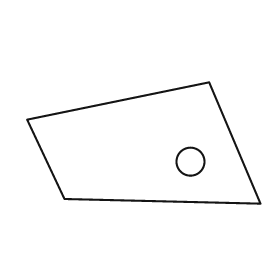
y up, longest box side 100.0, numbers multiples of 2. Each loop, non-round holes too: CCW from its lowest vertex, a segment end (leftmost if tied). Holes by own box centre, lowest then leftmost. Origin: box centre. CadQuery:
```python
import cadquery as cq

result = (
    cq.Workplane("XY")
    .moveTo(50.0, -26.0)
    .lineTo(28.0, 26.0)
    .lineTo(-50.0, 10.0)
    .lineTo(-34.0, -24.0)
    .close()
    .moveTo(20.0, -8.0)
    .circle(6.0)
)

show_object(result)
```